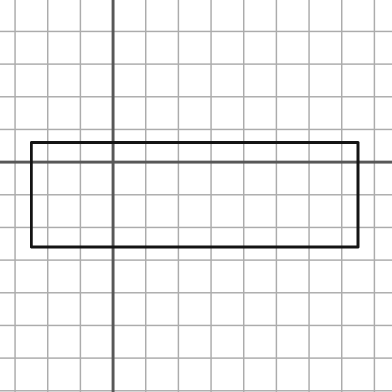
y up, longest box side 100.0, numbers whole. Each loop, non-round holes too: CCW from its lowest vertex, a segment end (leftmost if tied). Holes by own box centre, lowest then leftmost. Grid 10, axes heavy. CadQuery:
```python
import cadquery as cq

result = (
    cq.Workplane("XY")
    .moveTo(-25.0, -26.0)
    .lineTo(75.0, -26.0)
    .lineTo(75.0, 6.0)
    .lineTo(-25.0, 6.0)
    .close()
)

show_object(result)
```